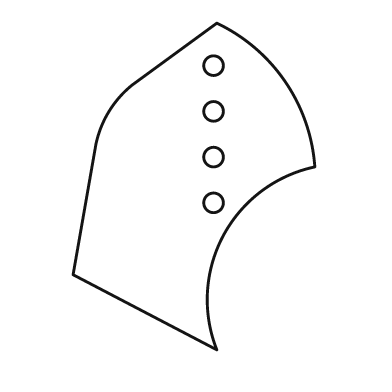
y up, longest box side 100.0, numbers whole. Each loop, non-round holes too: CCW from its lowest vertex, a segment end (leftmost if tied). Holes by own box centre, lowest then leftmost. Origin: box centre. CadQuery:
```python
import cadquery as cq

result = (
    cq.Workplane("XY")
    .moveTo(7.0, -50.0)
    .threePointArc((9.0, -15.0), (37.0, 6.0))
    .threePointArc((28.0, 32.0), (7.0, 50.0))
    .lineTo(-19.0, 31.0)
    .threePointArc((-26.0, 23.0), (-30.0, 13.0))
    .lineTo(-37.0, -27.0)
    .close()
    .moveTo(6.0, -5.0)
    .circle(3.0)
    .moveTo(6.0, 9.0)
    .circle(3.0)
    .moveTo(6.0, 23.0)
    .circle(3.0)
    .moveTo(6.0, 37.0)
    .circle(3.0)
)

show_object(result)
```